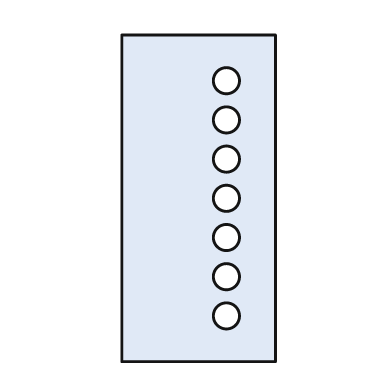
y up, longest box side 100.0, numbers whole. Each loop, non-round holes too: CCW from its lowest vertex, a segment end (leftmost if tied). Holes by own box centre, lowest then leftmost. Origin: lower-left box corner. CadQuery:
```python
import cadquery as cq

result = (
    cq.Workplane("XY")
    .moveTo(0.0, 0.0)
    .lineTo(47.0, 0.0)
    .lineTo(47.0, 100.0)
    .lineTo(0.0, 100.0)
    .close()
    .moveTo(32.0, 14.0)
    .circle(4.0)
    .moveTo(32.0, 26.0)
    .circle(4.0)
    .moveTo(32.0, 38.0)
    .circle(4.0)
    .moveTo(32.0, 50.0)
    .circle(4.0)
    .moveTo(32.0, 62.0)
    .circle(4.0)
    .moveTo(32.0, 74.0)
    .circle(4.0)
    .moveTo(32.0, 86.0)
    .circle(4.0)
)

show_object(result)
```